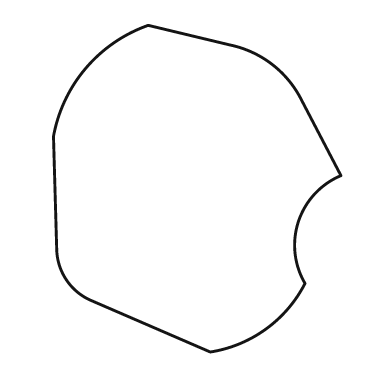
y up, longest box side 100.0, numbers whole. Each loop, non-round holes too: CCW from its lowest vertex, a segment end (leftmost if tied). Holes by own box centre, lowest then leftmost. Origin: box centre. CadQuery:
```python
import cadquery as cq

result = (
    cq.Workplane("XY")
    .moveTo(4.0, -50.0)
    .threePointArc((21.0, -43.0), (33.0, -29.0))
    .threePointArc((31.0, -10.0), (44.0, 4.0))
    .lineTo(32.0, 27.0)
    .threePointArc((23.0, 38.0), (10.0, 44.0))
    .lineTo(-15.0, 50.0)
    .threePointArc((-34.0, 37.0), (-44.0, 16.0))
    .lineTo(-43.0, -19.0)
    .threePointArc((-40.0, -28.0), (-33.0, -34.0))
    .close()
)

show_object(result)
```